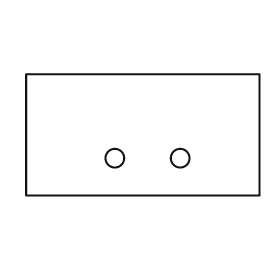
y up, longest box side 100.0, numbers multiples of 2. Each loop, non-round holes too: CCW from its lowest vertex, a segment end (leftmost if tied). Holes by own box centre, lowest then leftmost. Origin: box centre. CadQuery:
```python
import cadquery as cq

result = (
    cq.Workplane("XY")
    .moveTo(-50.0, -26.0)
    .lineTo(50.0, -26.0)
    .lineTo(50.0, 26.0)
    .lineTo(-50.0, 26.0)
    .close()
    .moveTo(-12.0, -10.0)
    .circle(4.0)
    .moveTo(16.0, -10.0)
    .circle(4.0)
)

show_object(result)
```